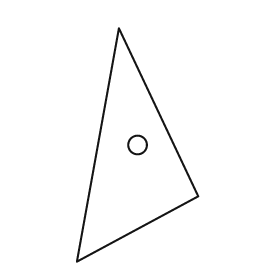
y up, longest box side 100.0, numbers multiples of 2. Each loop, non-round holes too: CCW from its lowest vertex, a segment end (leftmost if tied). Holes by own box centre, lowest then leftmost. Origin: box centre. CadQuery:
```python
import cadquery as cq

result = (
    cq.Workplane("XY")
    .moveTo(-26.0, -50.0)
    .lineTo(26.0, -22.0)
    .lineTo(-8.0, 50.0)
    .close()
    .moveTo(0.0, 0.0)
    .circle(4.0)
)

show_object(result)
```